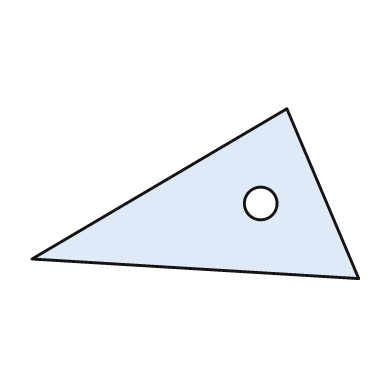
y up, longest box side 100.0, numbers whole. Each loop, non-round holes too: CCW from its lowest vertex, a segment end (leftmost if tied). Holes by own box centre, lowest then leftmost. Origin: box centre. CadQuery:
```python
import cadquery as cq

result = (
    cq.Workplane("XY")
    .moveTo(50.0, -26.0)
    .lineTo(28.0, 26.0)
    .lineTo(-50.0, -20.0)
    .close()
    .moveTo(20.0, -3.0)
    .circle(5.0)
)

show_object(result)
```